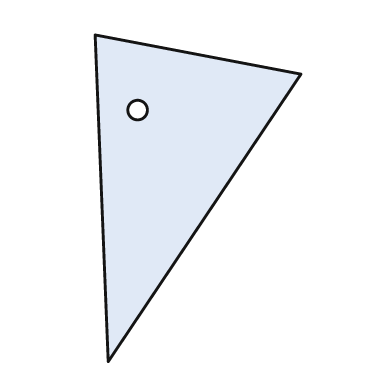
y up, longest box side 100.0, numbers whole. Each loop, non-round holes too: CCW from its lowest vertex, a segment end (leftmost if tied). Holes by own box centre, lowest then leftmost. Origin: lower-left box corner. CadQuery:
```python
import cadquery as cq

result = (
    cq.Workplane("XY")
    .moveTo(4.0, 0.0)
    .lineTo(63.0, 88.0)
    .lineTo(0.0, 100.0)
    .close()
    .moveTo(13.0, 77.0)
    .circle(3.0)
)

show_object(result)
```